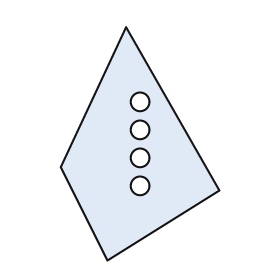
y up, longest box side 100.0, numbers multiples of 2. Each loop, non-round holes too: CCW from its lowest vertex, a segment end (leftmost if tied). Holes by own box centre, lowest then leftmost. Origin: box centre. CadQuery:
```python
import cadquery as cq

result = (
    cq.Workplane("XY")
    .moveTo(-14.0, -50.0)
    .lineTo(34.0, -20.0)
    .lineTo(-6.0, 50.0)
    .lineTo(-34.0, -10.0)
    .close()
    .moveTo(0.0, -18.0)
    .circle(4.0)
    .moveTo(0.0, -6.0)
    .circle(4.0)
    .moveTo(0.0, 6.0)
    .circle(4.0)
    .moveTo(0.0, 18.0)
    .circle(4.0)
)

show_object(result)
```